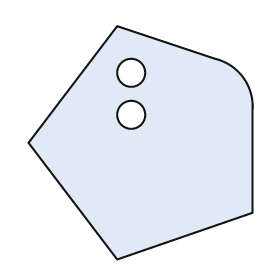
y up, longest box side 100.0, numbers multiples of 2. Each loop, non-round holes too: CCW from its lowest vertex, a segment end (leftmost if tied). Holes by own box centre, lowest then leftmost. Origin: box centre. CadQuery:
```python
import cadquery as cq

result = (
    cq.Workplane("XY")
    .moveTo(-10.0, -50.0)
    .lineTo(48.0, -30.0)
    .lineTo(48.0, 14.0)
    .threePointArc((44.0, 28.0), (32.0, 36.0))
    .lineTo(-10.0, 50.0)
    .lineTo(-48.0, 0.0)
    .close()
    .moveTo(-4.0, 12.0)
    .circle(6.0)
    .moveTo(-4.0, 30.0)
    .circle(6.0)
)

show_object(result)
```